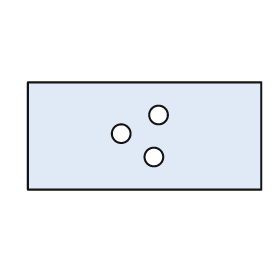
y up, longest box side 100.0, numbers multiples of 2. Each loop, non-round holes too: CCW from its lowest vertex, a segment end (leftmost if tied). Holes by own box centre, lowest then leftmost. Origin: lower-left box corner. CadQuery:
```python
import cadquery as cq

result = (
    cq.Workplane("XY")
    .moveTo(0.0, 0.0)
    .lineTo(100.0, 0.0)
    .lineTo(100.0, 46.0)
    .lineTo(0.0, 46.0)
    .close()
    .moveTo(54.0, 14.0)
    .circle(4.0)
    .moveTo(40.0, 24.0)
    .circle(4.0)
    .moveTo(56.0, 32.0)
    .circle(4.0)
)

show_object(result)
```